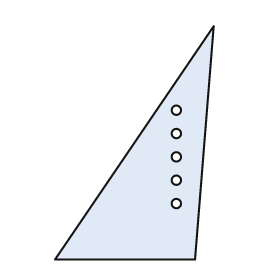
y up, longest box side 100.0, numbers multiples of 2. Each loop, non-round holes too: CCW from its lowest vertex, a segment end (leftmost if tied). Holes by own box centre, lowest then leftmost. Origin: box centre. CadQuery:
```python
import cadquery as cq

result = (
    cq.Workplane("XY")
    .moveTo(-34.0, -50.0)
    .lineTo(26.0, -50.0)
    .lineTo(34.0, 50.0)
    .close()
    .moveTo(18.0, -26.0)
    .circle(2.0)
    .moveTo(18.0, -16.0)
    .circle(2.0)
    .moveTo(18.0, -6.0)
    .circle(2.0)
    .moveTo(18.0, 4.0)
    .circle(2.0)
    .moveTo(18.0, 14.0)
    .circle(2.0)
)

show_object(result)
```